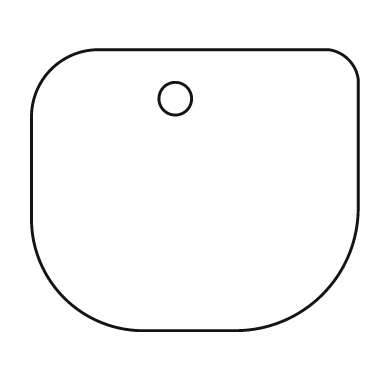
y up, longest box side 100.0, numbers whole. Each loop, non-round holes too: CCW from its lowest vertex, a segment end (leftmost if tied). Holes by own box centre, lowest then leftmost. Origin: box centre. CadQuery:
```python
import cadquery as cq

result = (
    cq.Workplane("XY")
    .moveTo(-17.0, -43.0)
    .lineTo(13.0, -43.0)
    .threePointArc((39.0, -32.0), (50.0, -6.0))
    .lineTo(50.0, 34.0)
    .threePointArc((47.0, 40.0), (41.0, 43.0))
    .lineTo(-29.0, 43.0)
    .threePointArc((-44.0, 37.0), (-50.0, 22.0))
    .lineTo(-50.0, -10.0)
    .threePointArc((-40.0, -33.0), (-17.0, -43.0))
    .close()
    .moveTo(-6.0, 28.0)
    .circle(5.0)
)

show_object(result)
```